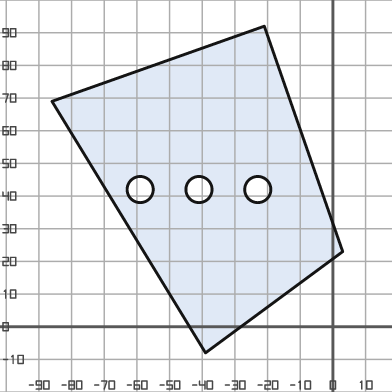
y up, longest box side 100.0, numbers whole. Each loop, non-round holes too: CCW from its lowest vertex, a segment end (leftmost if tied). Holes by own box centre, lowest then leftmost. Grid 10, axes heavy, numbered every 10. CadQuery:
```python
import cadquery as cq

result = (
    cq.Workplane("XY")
    .moveTo(-39.0, -8.0)
    .lineTo(3.0, 23.0)
    .lineTo(-21.0, 92.0)
    .lineTo(-86.0, 69.0)
    .close()
    .moveTo(-59.0, 42.0)
    .circle(4.0)
    .moveTo(-41.0, 42.0)
    .circle(4.0)
    .moveTo(-23.0, 42.0)
    .circle(4.0)
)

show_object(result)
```